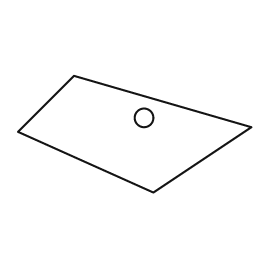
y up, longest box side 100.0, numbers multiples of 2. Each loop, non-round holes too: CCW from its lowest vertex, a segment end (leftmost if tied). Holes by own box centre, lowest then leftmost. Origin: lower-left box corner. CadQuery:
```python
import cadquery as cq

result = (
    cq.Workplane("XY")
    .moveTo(58.0, 0.0)
    .lineTo(100.0, 28.0)
    .lineTo(24.0, 50.0)
    .lineTo(0.0, 26.0)
    .close()
    .moveTo(54.0, 32.0)
    .circle(4.0)
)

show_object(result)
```